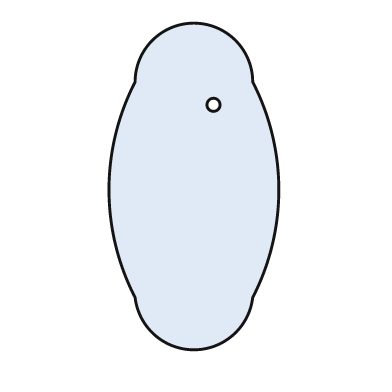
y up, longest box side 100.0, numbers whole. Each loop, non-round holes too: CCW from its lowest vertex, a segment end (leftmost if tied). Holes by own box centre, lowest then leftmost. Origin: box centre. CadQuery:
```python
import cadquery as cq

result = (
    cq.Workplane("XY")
    .moveTo(-18.0, -34.0)
    .threePointArc((0.0, -50.0), (18.0, -34.0))
    .threePointArc((26.0, -1.0), (18.0, 32.0))
    .threePointArc((0.0, 50.0), (-18.0, 32.0))
    .threePointArc((-26.0, -1.0), (-18.0, -34.0))
    .close()
    .moveTo(6.0, 25.0)
    .circle(2.0)
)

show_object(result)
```